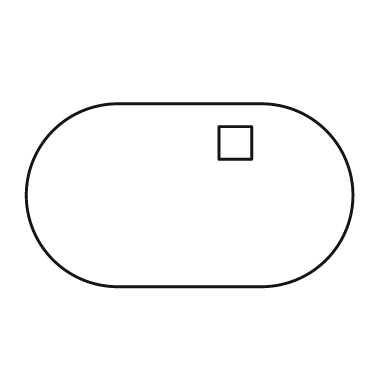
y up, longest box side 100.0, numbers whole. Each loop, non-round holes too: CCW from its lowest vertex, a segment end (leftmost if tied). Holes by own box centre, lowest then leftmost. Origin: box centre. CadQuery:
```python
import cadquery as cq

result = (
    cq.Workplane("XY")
    .moveTo(-22.0, -28.0)
    .lineTo(22.0, -28.0)
    .threePointArc((50.0, 0.0), (22.0, 28.0))
    .lineTo(-22.0, 28.0)
    .threePointArc((-50.0, 0.0), (-22.0, -28.0))
    .close()
    .moveTo(9.0, 11.0)
    .lineTo(19.0, 11.0)
    .lineTo(19.0, 21.0)
    .lineTo(9.0, 21.0)
    .close()
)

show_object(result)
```